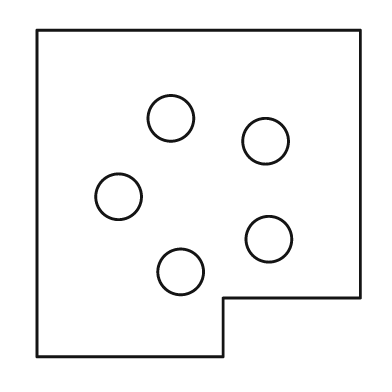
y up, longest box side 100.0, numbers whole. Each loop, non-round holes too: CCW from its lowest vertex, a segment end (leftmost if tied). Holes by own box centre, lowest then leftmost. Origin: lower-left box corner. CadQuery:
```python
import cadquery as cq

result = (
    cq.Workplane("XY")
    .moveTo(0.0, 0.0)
    .lineTo(57.0, 0.0)
    .lineTo(57.0, 18.0)
    .lineTo(99.0, 18.0)
    .lineTo(99.0, 100.0)
    .lineTo(0.0, 100.0)
    .close()
    .moveTo(44.0, 26.0)
    .circle(7.0)
    .moveTo(71.0, 36.0)
    .circle(7.0)
    .moveTo(25.0, 49.0)
    .circle(7.0)
    .moveTo(70.0, 66.0)
    .circle(7.0)
    .moveTo(41.0, 73.0)
    .circle(7.0)
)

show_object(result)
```